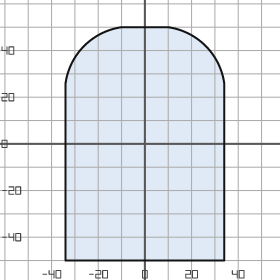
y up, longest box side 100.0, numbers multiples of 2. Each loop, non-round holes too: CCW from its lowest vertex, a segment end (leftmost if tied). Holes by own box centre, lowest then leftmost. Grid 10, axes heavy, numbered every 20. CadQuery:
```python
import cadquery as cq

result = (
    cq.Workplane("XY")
    .moveTo(-34.0, -50.0)
    .lineTo(34.0, -50.0)
    .lineTo(34.0, 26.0)
    .threePointArc((26.0, 42.0), (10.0, 50.0))
    .lineTo(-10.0, 50.0)
    .threePointArc((-26.0, 42.0), (-34.0, 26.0))
    .close()
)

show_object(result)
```